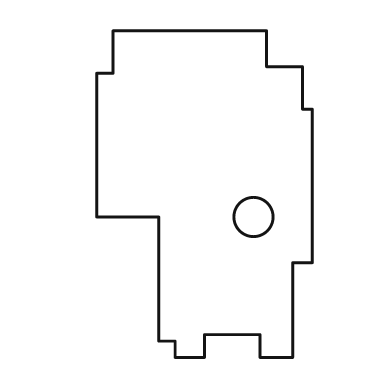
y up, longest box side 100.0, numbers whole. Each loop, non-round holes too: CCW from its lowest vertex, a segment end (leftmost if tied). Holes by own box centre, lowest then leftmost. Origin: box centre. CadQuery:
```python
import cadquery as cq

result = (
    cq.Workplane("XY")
    .moveTo(-9.0, -50.0)
    .lineTo(0.0, -50.0)
    .lineTo(0.0, -43.0)
    .lineTo(17.0, -43.0)
    .lineTo(17.0, -50.0)
    .lineTo(27.0, -50.0)
    .lineTo(27.0, -21.0)
    .lineTo(33.0, -21.0)
    .lineTo(33.0, 26.0)
    .lineTo(30.0, 26.0)
    .lineTo(30.0, 39.0)
    .lineTo(19.0, 39.0)
    .lineTo(19.0, 50.0)
    .lineTo(-28.0, 50.0)
    .lineTo(-28.0, 37.0)
    .lineTo(-33.0, 37.0)
    .lineTo(-33.0, -7.0)
    .lineTo(-14.0, -7.0)
    .lineTo(-14.0, -45.0)
    .lineTo(-9.0, -45.0)
    .close()
    .moveTo(15.0, -7.0)
    .circle(6.0)
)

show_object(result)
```